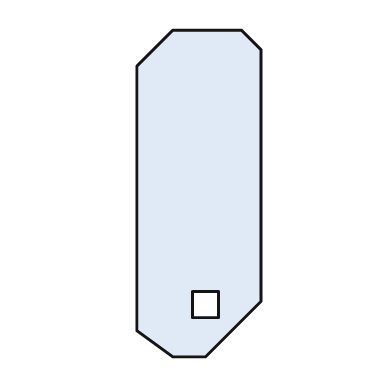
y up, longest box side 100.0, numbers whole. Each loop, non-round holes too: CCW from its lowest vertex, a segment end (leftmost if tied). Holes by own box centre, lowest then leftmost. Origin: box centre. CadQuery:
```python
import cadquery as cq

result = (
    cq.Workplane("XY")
    .moveTo(-8.0, -50.0)
    .lineTo(2.0, -50.0)
    .lineTo(19.0, -33.0)
    .lineTo(19.0, 44.0)
    .lineTo(13.0, 50.0)
    .lineTo(-8.0, 50.0)
    .lineTo(-19.0, 39.0)
    .lineTo(-19.0, -42.0)
    .close()
    .moveTo(-2.0, -38.0)
    .lineTo(6.0, -38.0)
    .lineTo(6.0, -30.0)
    .lineTo(-2.0, -30.0)
    .close()
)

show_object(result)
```